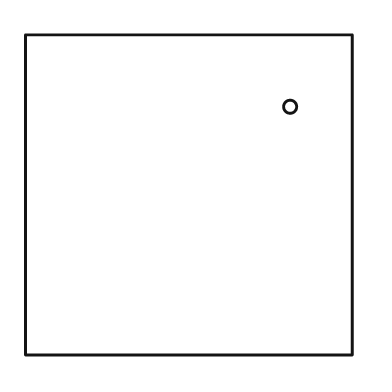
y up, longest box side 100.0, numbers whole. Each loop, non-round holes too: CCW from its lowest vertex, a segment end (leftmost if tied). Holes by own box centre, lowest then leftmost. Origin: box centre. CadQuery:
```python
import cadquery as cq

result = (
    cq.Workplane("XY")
    .moveTo(-50.0, -49.0)
    .lineTo(50.0, -49.0)
    .lineTo(50.0, 49.0)
    .lineTo(-50.0, 49.0)
    .close()
    .moveTo(31.0, 27.0)
    .circle(2.0)
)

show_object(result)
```